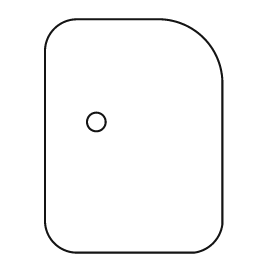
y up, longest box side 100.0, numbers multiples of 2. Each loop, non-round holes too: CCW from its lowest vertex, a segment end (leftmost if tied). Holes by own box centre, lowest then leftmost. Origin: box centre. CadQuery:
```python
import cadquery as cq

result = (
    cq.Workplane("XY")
    .moveTo(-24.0, -50.0)
    .lineTo(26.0, -50.0)
    .threePointArc((34.0, -46.0), (38.0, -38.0))
    .lineTo(38.0, 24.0)
    .threePointArc((30.0, 42.0), (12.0, 50.0))
    .lineTo(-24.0, 50.0)
    .threePointArc((-34.0, 46.0), (-38.0, 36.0))
    .lineTo(-38.0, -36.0)
    .threePointArc((-34.0, -46.0), (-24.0, -50.0))
    .close()
    .moveTo(-16.0, 6.0)
    .circle(4.0)
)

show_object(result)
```